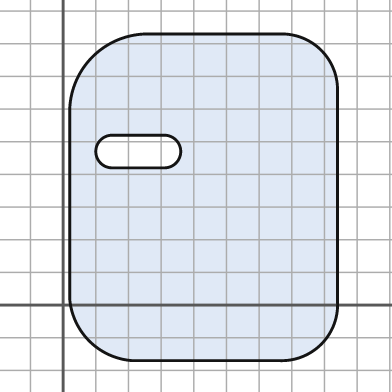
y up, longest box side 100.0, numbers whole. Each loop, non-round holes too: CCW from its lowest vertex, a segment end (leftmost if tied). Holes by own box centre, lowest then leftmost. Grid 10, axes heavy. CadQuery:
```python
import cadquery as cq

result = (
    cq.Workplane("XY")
    .moveTo(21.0, -17.0)
    .lineTo(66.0, -17.0)
    .threePointArc((79.0, -12.0), (84.0, 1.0))
    .lineTo(84.0, 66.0)
    .threePointArc((79.0, 78.0), (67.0, 83.0))
    .lineTo(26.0, 83.0)
    .threePointArc((9.0, 76.0), (2.0, 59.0))
    .lineTo(2.0, 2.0)
    .threePointArc((8.0, -11.0), (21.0, -17.0))
    .close()
    .moveTo(15.0, 42.0)
    .lineTo(31.0, 42.0)
    .threePointArc((36.0, 47.0), (31.0, 52.0))
    .lineTo(15.0, 52.0)
    .threePointArc((10.0, 47.0), (15.0, 42.0))
    .close()
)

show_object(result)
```